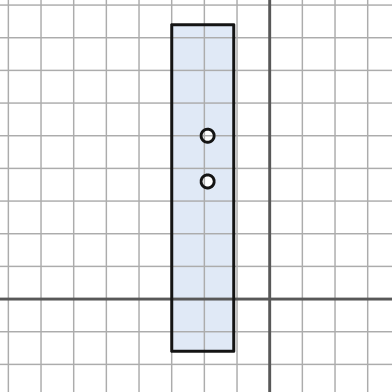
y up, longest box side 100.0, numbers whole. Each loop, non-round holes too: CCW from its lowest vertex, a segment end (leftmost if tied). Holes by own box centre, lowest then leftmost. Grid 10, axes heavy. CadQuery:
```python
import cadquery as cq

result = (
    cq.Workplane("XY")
    .moveTo(-30.0, -16.0)
    .lineTo(-11.0, -16.0)
    .lineTo(-11.0, 84.0)
    .lineTo(-30.0, 84.0)
    .close()
    .moveTo(-19.0, 36.0)
    .circle(2.0)
    .moveTo(-19.0, 50.0)
    .circle(2.0)
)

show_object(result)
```